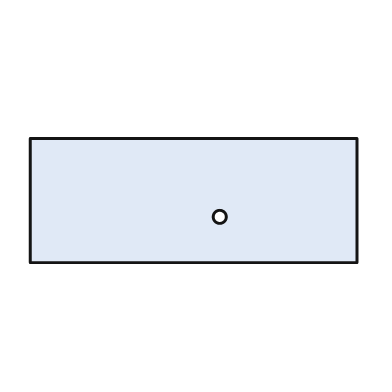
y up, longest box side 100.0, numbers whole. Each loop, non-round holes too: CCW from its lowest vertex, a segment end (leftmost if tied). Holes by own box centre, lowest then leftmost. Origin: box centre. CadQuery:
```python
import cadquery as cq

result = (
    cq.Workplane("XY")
    .moveTo(-50.0, -19.0)
    .lineTo(50.0, -19.0)
    .lineTo(50.0, 19.0)
    .lineTo(-50.0, 19.0)
    .close()
    .moveTo(8.0, -5.0)
    .circle(2.0)
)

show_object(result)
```